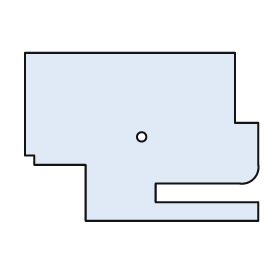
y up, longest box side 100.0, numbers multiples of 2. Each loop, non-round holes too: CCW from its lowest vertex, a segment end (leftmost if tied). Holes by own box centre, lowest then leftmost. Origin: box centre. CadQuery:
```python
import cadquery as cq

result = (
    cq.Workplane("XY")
    .moveTo(-24.0, -36.0)
    .lineTo(50.0, -36.0)
    .lineTo(50.0, -28.0)
    .lineTo(6.0, -28.0)
    .lineTo(6.0, -20.0)
    .lineTo(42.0, -20.0)
    .threePointArc((48.0, -18.0), (50.0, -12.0))
    .lineTo(50.0, 6.0)
    .lineTo(40.0, 6.0)
    .lineTo(40.0, 36.0)
    .lineTo(-50.0, 36.0)
    .lineTo(-50.0, -8.0)
    .lineTo(-46.0, -8.0)
    .lineTo(-46.0, -12.0)
    .lineTo(-24.0, -12.0)
    .close()
    .moveTo(0.0, 0.0)
    .circle(2.0)
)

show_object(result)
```